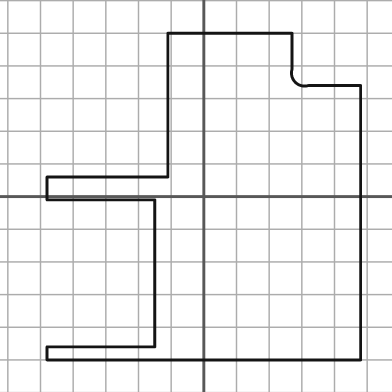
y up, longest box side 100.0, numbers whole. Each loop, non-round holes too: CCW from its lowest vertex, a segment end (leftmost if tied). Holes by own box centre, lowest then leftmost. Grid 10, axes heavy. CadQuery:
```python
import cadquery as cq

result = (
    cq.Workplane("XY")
    .moveTo(-48.0, -50.0)
    .lineTo(48.0, -50.0)
    .lineTo(48.0, 34.0)
    .lineTo(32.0, 34.0)
    .threePointArc((28.0, 35.0), (27.0, 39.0))
    .lineTo(27.0, 50.0)
    .lineTo(-11.0, 50.0)
    .lineTo(-11.0, 6.0)
    .lineTo(-48.0, 6.0)
    .lineTo(-48.0, -1.0)
    .lineTo(-15.0, -1.0)
    .lineTo(-15.0, -46.0)
    .lineTo(-48.0, -46.0)
    .close()
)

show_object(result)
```